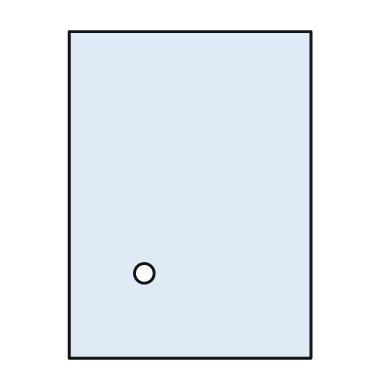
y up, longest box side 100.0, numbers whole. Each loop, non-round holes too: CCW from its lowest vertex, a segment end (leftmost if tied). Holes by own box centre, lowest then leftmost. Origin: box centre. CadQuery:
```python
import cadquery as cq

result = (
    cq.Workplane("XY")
    .moveTo(-37.0, -50.0)
    .lineTo(37.0, -50.0)
    .lineTo(37.0, 50.0)
    .lineTo(-37.0, 50.0)
    .close()
    .moveTo(-14.0, -24.0)
    .circle(3.0)
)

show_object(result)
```